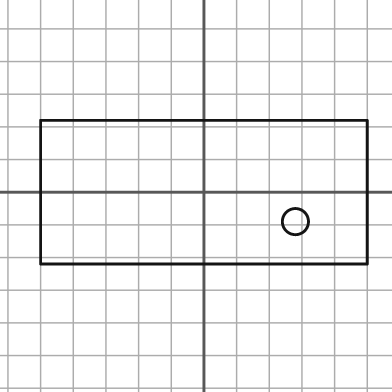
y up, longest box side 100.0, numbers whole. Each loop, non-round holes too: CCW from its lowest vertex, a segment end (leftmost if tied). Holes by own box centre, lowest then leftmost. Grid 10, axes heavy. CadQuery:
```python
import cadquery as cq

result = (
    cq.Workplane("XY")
    .moveTo(-50.0, -22.0)
    .lineTo(50.0, -22.0)
    .lineTo(50.0, 22.0)
    .lineTo(-50.0, 22.0)
    .close()
    .moveTo(28.0, -9.0)
    .circle(4.0)
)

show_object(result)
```